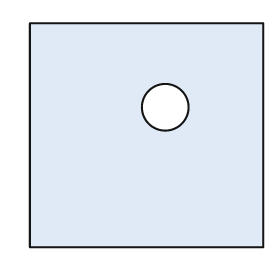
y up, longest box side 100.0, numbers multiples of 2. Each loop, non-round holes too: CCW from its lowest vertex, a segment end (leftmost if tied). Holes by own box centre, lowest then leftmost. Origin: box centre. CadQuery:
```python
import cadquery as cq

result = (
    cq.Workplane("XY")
    .moveTo(-50.0, -48.0)
    .lineTo(50.0, -48.0)
    .lineTo(50.0, 48.0)
    .lineTo(-50.0, 48.0)
    .close()
    .moveTo(8.0, 12.0)
    .circle(10.0)
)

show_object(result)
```